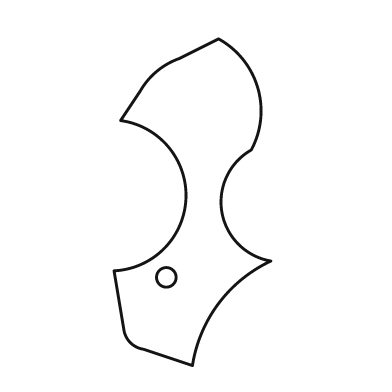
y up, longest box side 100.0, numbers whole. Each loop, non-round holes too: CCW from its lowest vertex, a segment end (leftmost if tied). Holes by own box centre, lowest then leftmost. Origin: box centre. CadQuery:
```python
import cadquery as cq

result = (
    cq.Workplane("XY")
    .moveTo(0.0, -50.0)
    .threePointArc((8.0, -31.0), (24.0, -18.0))
    .threePointArc((9.0, -3.0), (18.0, 16.0))
    .threePointArc((20.0, 35.0), (8.0, 50.0))
    .lineTo(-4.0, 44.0)
    .threePointArc((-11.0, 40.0), (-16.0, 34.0))
    .lineTo(-22.0, 25.0)
    .threePointArc((-2.0, 1.0), (-24.0, -21.0))
    .lineTo(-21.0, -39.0)
    .threePointArc((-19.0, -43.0), (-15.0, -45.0))
    .close()
    .moveTo(-8.0, -23.0)
    .circle(3.0)
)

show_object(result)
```